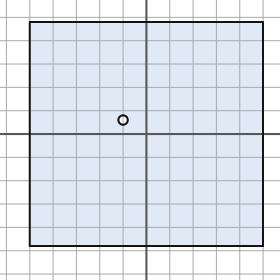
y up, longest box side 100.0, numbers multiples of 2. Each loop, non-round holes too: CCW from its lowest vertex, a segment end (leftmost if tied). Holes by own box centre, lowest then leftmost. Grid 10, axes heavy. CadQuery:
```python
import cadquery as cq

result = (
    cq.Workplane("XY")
    .moveTo(-50.0, -48.0)
    .lineTo(50.0, -48.0)
    .lineTo(50.0, 48.0)
    .lineTo(-50.0, 48.0)
    .close()
    .moveTo(-10.0, 6.0)
    .circle(2.0)
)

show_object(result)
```